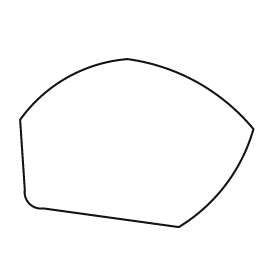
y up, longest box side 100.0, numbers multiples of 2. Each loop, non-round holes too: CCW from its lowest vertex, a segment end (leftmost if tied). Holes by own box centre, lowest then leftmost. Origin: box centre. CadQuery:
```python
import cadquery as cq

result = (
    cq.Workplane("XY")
    .moveTo(18.0, -36.0)
    .threePointArc((38.0, -18.0), (50.0, 6.0))
    .threePointArc((26.0, 26.0), (-4.0, 36.0))
    .threePointArc((-30.0, 28.0), (-50.0, 10.0))
    .lineTo(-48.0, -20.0)
    .threePointArc((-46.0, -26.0), (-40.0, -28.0))
    .close()
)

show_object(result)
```